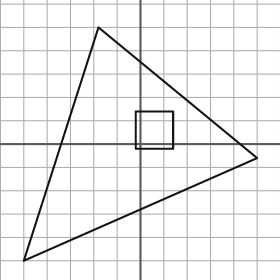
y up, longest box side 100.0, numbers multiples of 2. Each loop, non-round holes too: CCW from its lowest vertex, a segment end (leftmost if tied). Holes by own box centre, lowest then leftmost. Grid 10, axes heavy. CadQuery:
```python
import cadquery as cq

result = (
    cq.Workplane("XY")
    .moveTo(-50.0, -50.0)
    .lineTo(50.0, -6.0)
    .lineTo(-18.0, 50.0)
    .close()
    .moveTo(-2.0, -2.0)
    .lineTo(14.0, -2.0)
    .lineTo(14.0, 14.0)
    .lineTo(-2.0, 14.0)
    .close()
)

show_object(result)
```